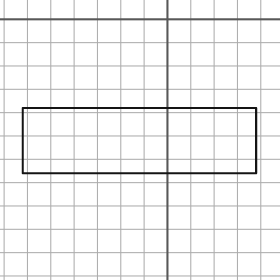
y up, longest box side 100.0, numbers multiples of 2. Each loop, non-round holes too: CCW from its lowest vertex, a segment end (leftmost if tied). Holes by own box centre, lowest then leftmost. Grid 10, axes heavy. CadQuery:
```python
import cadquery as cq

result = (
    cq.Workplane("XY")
    .moveTo(-62.0, -66.0)
    .lineTo(38.0, -66.0)
    .lineTo(38.0, -38.0)
    .lineTo(-62.0, -38.0)
    .close()
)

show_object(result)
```